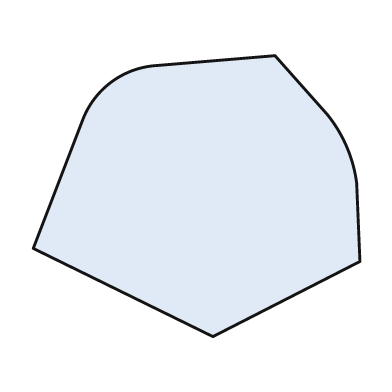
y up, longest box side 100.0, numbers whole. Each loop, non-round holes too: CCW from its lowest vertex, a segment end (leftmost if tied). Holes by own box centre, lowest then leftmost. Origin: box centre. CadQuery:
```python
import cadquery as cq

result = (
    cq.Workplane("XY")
    .moveTo(5.0, -43.0)
    .lineTo(50.0, -20.0)
    .lineTo(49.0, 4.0)
    .threePointArc((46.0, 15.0), (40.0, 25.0))
    .lineTo(24.0, 43.0)
    .lineTo(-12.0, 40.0)
    .threePointArc((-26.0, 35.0), (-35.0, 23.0))
    .lineTo(-50.0, -16.0)
    .close()
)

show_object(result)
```